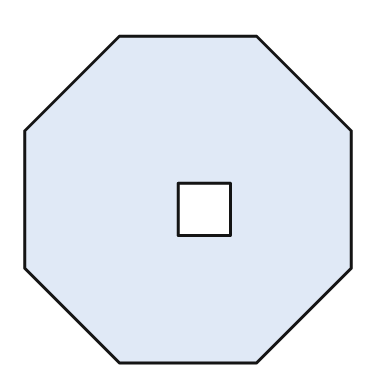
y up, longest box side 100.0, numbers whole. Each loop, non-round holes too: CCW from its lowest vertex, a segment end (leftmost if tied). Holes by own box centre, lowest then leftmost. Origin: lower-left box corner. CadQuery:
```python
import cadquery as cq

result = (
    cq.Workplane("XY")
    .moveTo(29.0, 0.0)
    .lineTo(71.0, 0.0)
    .lineTo(100.0, 29.0)
    .lineTo(100.0, 71.0)
    .lineTo(71.0, 100.0)
    .lineTo(29.0, 100.0)
    .lineTo(0.0, 71.0)
    .lineTo(0.0, 29.0)
    .close()
    .moveTo(47.0, 39.0)
    .lineTo(63.0, 39.0)
    .lineTo(63.0, 55.0)
    .lineTo(47.0, 55.0)
    .close()
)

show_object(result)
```